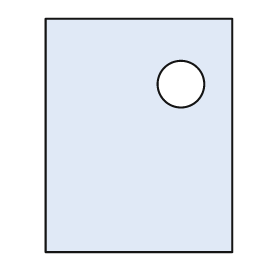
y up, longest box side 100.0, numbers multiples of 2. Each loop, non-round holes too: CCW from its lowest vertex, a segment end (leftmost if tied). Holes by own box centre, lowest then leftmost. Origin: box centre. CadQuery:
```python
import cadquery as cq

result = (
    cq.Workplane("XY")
    .moveTo(-40.0, -50.0)
    .lineTo(40.0, -50.0)
    .lineTo(40.0, 50.0)
    .lineTo(-40.0, 50.0)
    .close()
    .moveTo(18.0, 22.0)
    .circle(10.0)
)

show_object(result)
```